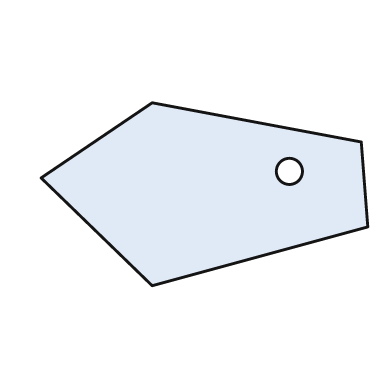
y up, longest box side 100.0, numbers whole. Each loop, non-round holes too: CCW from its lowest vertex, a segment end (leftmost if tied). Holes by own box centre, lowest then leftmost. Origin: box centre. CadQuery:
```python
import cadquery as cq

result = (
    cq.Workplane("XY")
    .moveTo(-16.0, -28.0)
    .lineTo(50.0, -10.0)
    .lineTo(48.0, 16.0)
    .lineTo(-16.0, 28.0)
    .lineTo(-50.0, 5.0)
    .close()
    .moveTo(26.0, 7.0)
    .circle(4.0)
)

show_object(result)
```